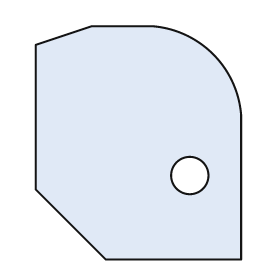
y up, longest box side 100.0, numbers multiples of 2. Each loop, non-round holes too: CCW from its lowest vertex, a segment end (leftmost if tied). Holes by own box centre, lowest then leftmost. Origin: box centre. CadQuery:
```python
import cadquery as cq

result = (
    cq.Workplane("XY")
    .moveTo(-14.0, -50.0)
    .lineTo(44.0, -50.0)
    .lineTo(44.0, 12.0)
    .threePointArc((32.0, 38.0), (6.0, 50.0))
    .lineTo(-20.0, 50.0)
    .lineTo(-44.0, 42.0)
    .lineTo(-44.0, -20.0)
    .close()
    .moveTo(22.0, -14.0)
    .circle(8.0)
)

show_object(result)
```